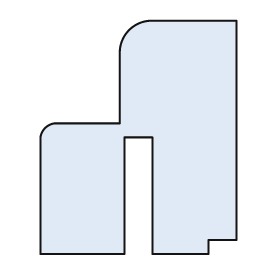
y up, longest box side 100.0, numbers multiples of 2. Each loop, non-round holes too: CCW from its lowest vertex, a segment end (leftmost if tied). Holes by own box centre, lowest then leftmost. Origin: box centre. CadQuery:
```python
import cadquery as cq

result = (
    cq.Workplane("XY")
    .moveTo(-42.0, -50.0)
    .lineTo(-6.0, -50.0)
    .lineTo(-6.0, 0.0)
    .lineTo(6.0, 0.0)
    .lineTo(6.0, -50.0)
    .lineTo(30.0, -50.0)
    .lineTo(30.0, -44.0)
    .lineTo(42.0, -44.0)
    .lineTo(42.0, 50.0)
    .lineTo(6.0, 50.0)
    .threePointArc((-4.0, 46.0), (-8.0, 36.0))
    .lineTo(-8.0, 6.0)
    .lineTo(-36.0, 6.0)
    .threePointArc((-40.0, 4.0), (-42.0, 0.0))
    .close()
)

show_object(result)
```